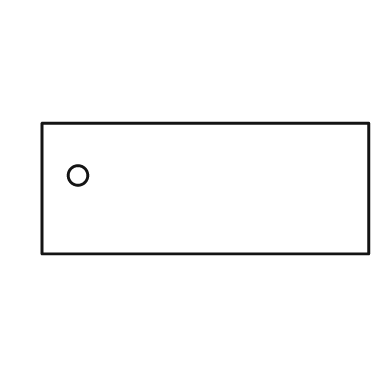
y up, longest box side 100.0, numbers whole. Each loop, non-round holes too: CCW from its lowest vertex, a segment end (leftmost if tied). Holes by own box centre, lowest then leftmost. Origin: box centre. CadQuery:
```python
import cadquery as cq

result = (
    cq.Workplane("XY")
    .moveTo(-50.0, -20.0)
    .lineTo(50.0, -20.0)
    .lineTo(50.0, 20.0)
    .lineTo(-50.0, 20.0)
    .close()
    .moveTo(-39.0, 4.0)
    .circle(3.0)
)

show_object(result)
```